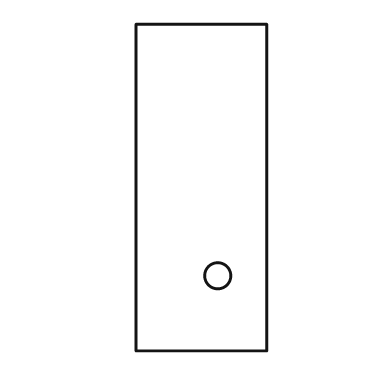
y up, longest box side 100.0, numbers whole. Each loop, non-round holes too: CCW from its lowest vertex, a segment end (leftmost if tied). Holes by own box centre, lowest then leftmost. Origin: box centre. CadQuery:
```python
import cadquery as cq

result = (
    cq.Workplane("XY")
    .moveTo(-20.0, -50.0)
    .lineTo(20.0, -50.0)
    .lineTo(20.0, 50.0)
    .lineTo(-20.0, 50.0)
    .close()
    .moveTo(5.0, -27.0)
    .circle(4.0)
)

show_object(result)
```